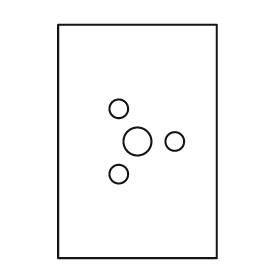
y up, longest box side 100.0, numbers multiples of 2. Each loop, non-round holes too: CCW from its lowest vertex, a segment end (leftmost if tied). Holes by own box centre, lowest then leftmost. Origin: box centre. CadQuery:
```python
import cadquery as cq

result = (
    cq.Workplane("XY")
    .moveTo(-34.0, -50.0)
    .lineTo(34.0, -50.0)
    .lineTo(34.0, 50.0)
    .lineTo(-34.0, 50.0)
    .close()
    .moveTo(-8.0, -14.0)
    .circle(4.0)
    .moveTo(0.0, 0.0)
    .circle(6.0)
    .moveTo(16.0, 0.0)
    .circle(4.0)
    .moveTo(-8.0, 14.0)
    .circle(4.0)
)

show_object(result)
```